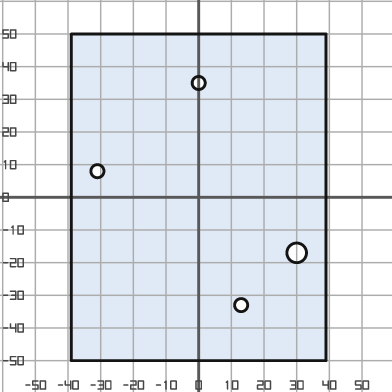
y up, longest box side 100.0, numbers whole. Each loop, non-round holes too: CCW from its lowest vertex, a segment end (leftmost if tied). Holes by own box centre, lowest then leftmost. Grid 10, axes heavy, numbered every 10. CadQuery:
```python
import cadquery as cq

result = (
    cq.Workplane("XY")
    .moveTo(-39.0, -50.0)
    .lineTo(39.0, -50.0)
    .lineTo(39.0, 50.0)
    .lineTo(-39.0, 50.0)
    .close()
    .moveTo(13.0, -33.0)
    .circle(2.0)
    .moveTo(30.0, -17.0)
    .circle(3.0)
    .moveTo(-31.0, 8.0)
    .circle(2.0)
    .moveTo(0.0, 35.0)
    .circle(2.0)
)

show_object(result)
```